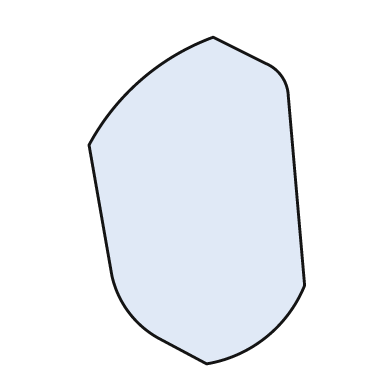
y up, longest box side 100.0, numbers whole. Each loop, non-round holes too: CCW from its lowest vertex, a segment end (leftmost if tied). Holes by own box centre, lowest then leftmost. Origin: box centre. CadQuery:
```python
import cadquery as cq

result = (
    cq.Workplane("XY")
    .moveTo(3.0, -50.0)
    .threePointArc((21.0, -42.0), (33.0, -26.0))
    .lineTo(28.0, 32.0)
    .threePointArc((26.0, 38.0), (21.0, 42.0))
    .lineTo(5.0, 50.0)
    .threePointArc((-17.0, 37.0), (-33.0, 17.0))
    .lineTo(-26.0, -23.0)
    .threePointArc((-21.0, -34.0), (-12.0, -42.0))
    .close()
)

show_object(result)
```